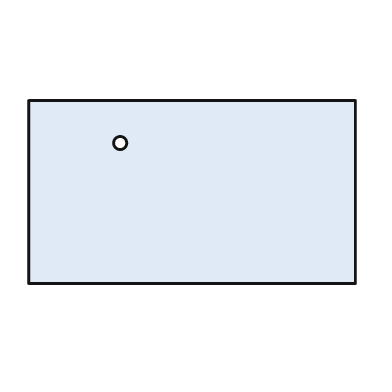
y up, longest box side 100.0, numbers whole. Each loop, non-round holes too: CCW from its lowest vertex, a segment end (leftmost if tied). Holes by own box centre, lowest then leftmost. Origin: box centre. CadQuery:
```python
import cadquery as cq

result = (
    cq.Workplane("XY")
    .moveTo(-50.0, -28.0)
    .lineTo(50.0, -28.0)
    .lineTo(50.0, 28.0)
    .lineTo(-50.0, 28.0)
    .close()
    .moveTo(-22.0, 15.0)
    .circle(2.0)
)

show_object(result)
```